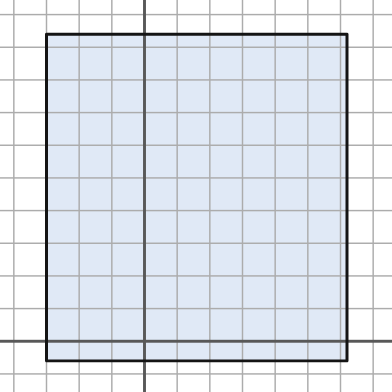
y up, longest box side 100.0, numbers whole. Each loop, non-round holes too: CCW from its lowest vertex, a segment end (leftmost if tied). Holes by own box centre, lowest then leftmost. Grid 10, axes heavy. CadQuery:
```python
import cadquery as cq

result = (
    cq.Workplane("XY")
    .moveTo(-30.0, -6.0)
    .lineTo(62.0, -6.0)
    .lineTo(62.0, 94.0)
    .lineTo(-30.0, 94.0)
    .close()
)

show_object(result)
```